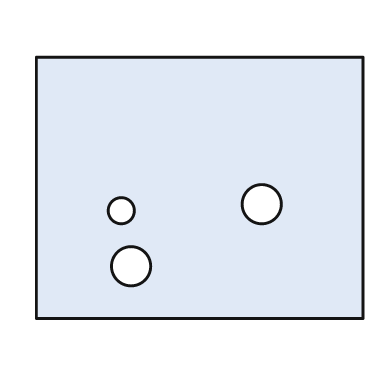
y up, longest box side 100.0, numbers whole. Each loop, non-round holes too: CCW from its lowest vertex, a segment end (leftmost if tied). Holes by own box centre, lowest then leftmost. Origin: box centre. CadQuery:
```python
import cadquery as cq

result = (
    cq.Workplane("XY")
    .moveTo(-50.0, -40.0)
    .lineTo(50.0, -40.0)
    .lineTo(50.0, 40.0)
    .lineTo(-50.0, 40.0)
    .close()
    .moveTo(-21.0, -24.0)
    .circle(6.0)
    .moveTo(-24.0, -7.0)
    .circle(4.0)
    .moveTo(19.0, -5.0)
    .circle(6.0)
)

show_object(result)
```